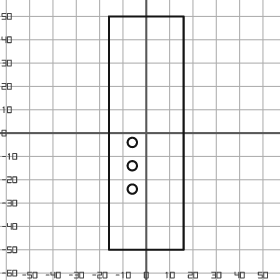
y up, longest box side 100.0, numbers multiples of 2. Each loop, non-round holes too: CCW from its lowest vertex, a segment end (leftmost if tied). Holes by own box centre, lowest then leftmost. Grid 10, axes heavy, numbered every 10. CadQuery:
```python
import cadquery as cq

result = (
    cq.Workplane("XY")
    .moveTo(-16.0, -50.0)
    .lineTo(16.0, -50.0)
    .lineTo(16.0, 50.0)
    .lineTo(-16.0, 50.0)
    .close()
    .moveTo(-6.0, -24.0)
    .circle(2.0)
    .moveTo(-6.0, -14.0)
    .circle(2.0)
    .moveTo(-6.0, -4.0)
    .circle(2.0)
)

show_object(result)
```